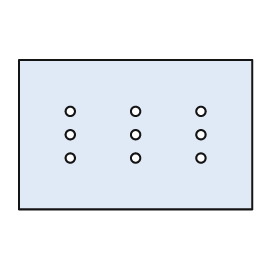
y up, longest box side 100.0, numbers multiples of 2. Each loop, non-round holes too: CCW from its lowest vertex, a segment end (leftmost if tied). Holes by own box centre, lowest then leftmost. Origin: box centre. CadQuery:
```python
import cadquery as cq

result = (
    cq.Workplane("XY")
    .moveTo(-50.0, -32.0)
    .lineTo(50.0, -32.0)
    .lineTo(50.0, 32.0)
    .lineTo(-50.0, 32.0)
    .close()
    .moveTo(-28.0, -10.0)
    .circle(2.0)
    .moveTo(0.0, -10.0)
    .circle(2.0)
    .moveTo(28.0, -10.0)
    .circle(2.0)
    .moveTo(-28.0, 0.0)
    .circle(2.0)
    .moveTo(0.0, 0.0)
    .circle(2.0)
    .moveTo(28.0, 0.0)
    .circle(2.0)
    .moveTo(-28.0, 10.0)
    .circle(2.0)
    .moveTo(0.0, 10.0)
    .circle(2.0)
    .moveTo(28.0, 10.0)
    .circle(2.0)
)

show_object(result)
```